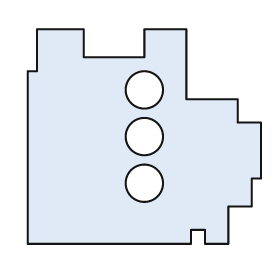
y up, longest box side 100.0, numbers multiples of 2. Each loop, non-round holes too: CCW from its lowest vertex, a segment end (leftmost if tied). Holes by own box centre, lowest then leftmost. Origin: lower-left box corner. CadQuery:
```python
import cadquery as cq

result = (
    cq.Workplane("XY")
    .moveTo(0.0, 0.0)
    .lineTo(70.0, 0.0)
    .lineTo(70.0, 6.0)
    .lineTo(76.0, 6.0)
    .lineTo(76.0, 0.0)
    .lineTo(86.0, 0.0)
    .lineTo(86.0, 16.0)
    .lineTo(96.0, 16.0)
    .lineTo(96.0, 28.0)
    .lineTo(100.0, 28.0)
    .lineTo(100.0, 52.0)
    .lineTo(90.0, 52.0)
    .lineTo(90.0, 62.0)
    .lineTo(68.0, 62.0)
    .lineTo(68.0, 92.0)
    .lineTo(50.0, 92.0)
    .lineTo(50.0, 80.0)
    .lineTo(24.0, 80.0)
    .lineTo(24.0, 92.0)
    .lineTo(4.0, 92.0)
    .lineTo(4.0, 74.0)
    .lineTo(0.0, 74.0)
    .close()
    .moveTo(50.0, 26.0)
    .circle(8.0)
    .moveTo(50.0, 46.0)
    .circle(8.0)
    .moveTo(50.0, 66.0)
    .circle(8.0)
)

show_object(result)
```